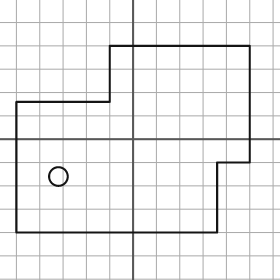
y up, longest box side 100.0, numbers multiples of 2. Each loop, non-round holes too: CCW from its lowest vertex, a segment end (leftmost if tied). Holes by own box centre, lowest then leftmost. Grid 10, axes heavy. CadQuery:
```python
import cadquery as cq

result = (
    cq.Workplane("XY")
    .moveTo(-50.0, -40.0)
    .lineTo(36.0, -40.0)
    .lineTo(36.0, -10.0)
    .lineTo(50.0, -10.0)
    .lineTo(50.0, 40.0)
    .lineTo(-10.0, 40.0)
    .lineTo(-10.0, 16.0)
    .lineTo(-50.0, 16.0)
    .close()
    .moveTo(-32.0, -16.0)
    .circle(4.0)
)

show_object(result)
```